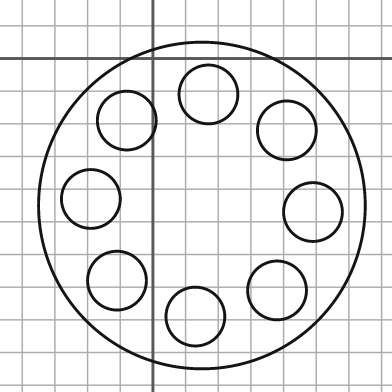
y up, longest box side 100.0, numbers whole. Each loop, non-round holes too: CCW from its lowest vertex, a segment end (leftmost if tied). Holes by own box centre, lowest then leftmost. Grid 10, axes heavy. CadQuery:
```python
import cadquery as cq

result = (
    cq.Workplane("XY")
    .moveTo(15.0, -45.0)
    .circle(50.0)
    .moveTo(13.0, -79.0)
    .circle(9.0)
    .moveTo(38.0, -71.0)
    .circle(9.0)
    .moveTo(-11.0, -68.0)
    .circle(9.0)
    .moveTo(49.0, -47.0)
    .circle(9.0)
    .moveTo(-19.0, -43.0)
    .circle(9.0)
    .moveTo(41.0, -22.0)
    .circle(9.0)
    .moveTo(-8.0, -19.0)
    .circle(9.0)
    .moveTo(17.0, -11.0)
    .circle(9.0)
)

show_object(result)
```